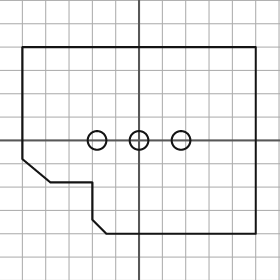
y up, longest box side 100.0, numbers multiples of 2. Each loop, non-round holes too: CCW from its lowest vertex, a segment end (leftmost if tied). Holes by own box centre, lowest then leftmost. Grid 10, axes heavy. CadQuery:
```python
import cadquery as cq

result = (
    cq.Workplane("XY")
    .moveTo(-14.0, -40.0)
    .lineTo(50.0, -40.0)
    .lineTo(50.0, 40.0)
    .lineTo(-50.0, 40.0)
    .lineTo(-50.0, -8.0)
    .lineTo(-38.0, -18.0)
    .lineTo(-20.0, -18.0)
    .lineTo(-20.0, -34.0)
    .close()
    .moveTo(-18.0, 0.0)
    .circle(4.0)
    .moveTo(0.0, 0.0)
    .circle(4.0)
    .moveTo(18.0, 0.0)
    .circle(4.0)
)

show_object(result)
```